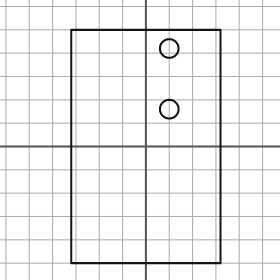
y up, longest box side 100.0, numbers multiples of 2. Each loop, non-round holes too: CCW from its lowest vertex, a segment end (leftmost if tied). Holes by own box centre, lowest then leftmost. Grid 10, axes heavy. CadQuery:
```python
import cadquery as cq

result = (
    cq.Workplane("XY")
    .moveTo(-32.0, -50.0)
    .lineTo(32.0, -50.0)
    .lineTo(32.0, 50.0)
    .lineTo(-32.0, 50.0)
    .close()
    .moveTo(10.0, 16.0)
    .circle(4.0)
    .moveTo(10.0, 42.0)
    .circle(4.0)
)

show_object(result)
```